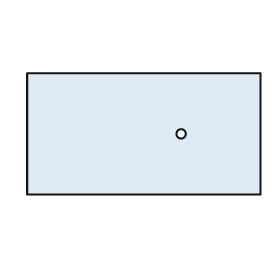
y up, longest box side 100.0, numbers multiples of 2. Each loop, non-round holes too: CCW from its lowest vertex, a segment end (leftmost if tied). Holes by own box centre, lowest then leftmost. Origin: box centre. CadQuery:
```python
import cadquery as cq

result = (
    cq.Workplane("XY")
    .moveTo(-50.0, -26.0)
    .lineTo(50.0, -26.0)
    .lineTo(50.0, 26.0)
    .lineTo(-50.0, 26.0)
    .close()
    .moveTo(16.0, 0.0)
    .circle(2.0)
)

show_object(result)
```